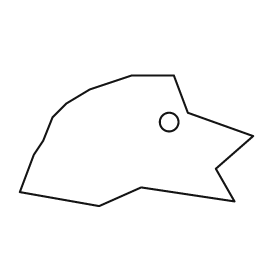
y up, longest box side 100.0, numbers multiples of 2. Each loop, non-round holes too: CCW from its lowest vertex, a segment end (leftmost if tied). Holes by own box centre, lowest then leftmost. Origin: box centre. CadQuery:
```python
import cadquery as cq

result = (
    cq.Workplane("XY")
    .moveTo(-16.0, -28.0)
    .lineTo(2.0, -20.0)
    .lineTo(42.0, -26.0)
    .lineTo(34.0, -12.0)
    .lineTo(50.0, 2.0)
    .lineTo(22.0, 12.0)
    .lineTo(16.0, 28.0)
    .lineTo(-2.0, 28.0)
    .lineTo(-20.0, 22.0)
    .lineTo(-30.0, 16.0)
    .lineTo(-36.0, 10.0)
    .lineTo(-40.0, 0.0)
    .lineTo(-44.0, -6.0)
    .lineTo(-50.0, -22.0)
    .close()
    .moveTo(14.0, 8.0)
    .circle(4.0)
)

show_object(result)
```